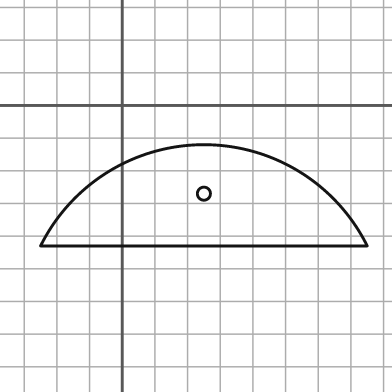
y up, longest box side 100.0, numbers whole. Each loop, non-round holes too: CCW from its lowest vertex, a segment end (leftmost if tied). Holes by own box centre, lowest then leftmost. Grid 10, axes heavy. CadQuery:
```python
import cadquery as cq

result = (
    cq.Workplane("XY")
    .moveTo(-25.0, -43.0)
    .lineTo(75.0, -43.0)
    .threePointArc((25.0, -12.0), (-25.0, -43.0))
    .close()
    .moveTo(25.0, -27.0)
    .circle(2.0)
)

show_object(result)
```